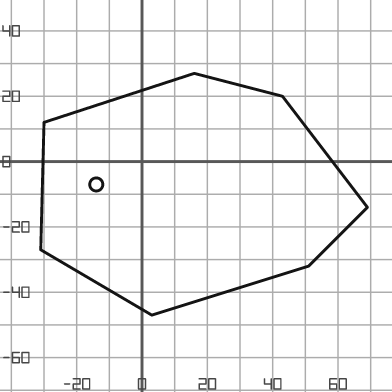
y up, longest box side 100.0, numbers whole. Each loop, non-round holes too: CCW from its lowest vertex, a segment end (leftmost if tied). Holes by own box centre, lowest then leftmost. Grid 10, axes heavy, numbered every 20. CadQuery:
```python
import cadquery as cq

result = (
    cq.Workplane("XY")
    .moveTo(3.0, -47.0)
    .lineTo(51.0, -32.0)
    .lineTo(69.0, -14.0)
    .lineTo(43.0, 20.0)
    .lineTo(16.0, 27.0)
    .lineTo(-30.0, 12.0)
    .lineTo(-31.0, -27.0)
    .close()
    .moveTo(-14.0, -7.0)
    .circle(2.0)
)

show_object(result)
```